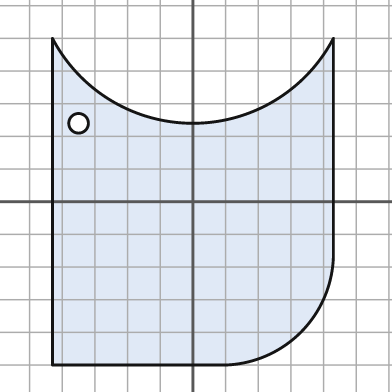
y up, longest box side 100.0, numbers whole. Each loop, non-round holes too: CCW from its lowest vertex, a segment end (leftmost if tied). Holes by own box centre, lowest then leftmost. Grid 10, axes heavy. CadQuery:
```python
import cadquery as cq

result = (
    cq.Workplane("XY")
    .moveTo(-43.0, -50.0)
    .lineTo(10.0, -50.0)
    .threePointArc((33.0, -40.0), (43.0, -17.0))
    .lineTo(43.0, 50.0)
    .threePointArc((0.0, 24.0), (-43.0, 50.0))
    .close()
    .moveTo(-35.0, 24.0)
    .circle(3.0)
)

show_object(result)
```